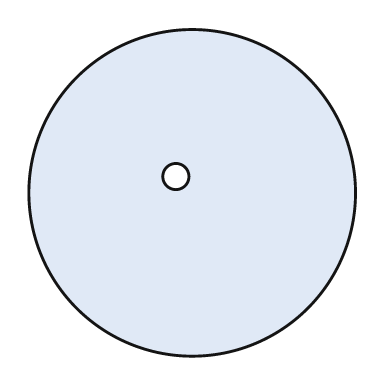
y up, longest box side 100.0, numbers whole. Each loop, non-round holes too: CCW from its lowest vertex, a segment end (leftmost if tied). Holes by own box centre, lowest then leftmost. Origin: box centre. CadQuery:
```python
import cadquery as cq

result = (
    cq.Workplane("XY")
    .moveTo(0.0, 0.0)
    .circle(50.0)
    .moveTo(-5.0, 5.0)
    .circle(4.0)
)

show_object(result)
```